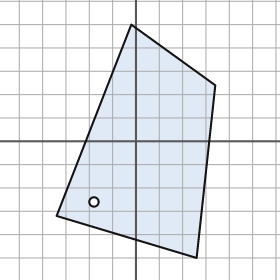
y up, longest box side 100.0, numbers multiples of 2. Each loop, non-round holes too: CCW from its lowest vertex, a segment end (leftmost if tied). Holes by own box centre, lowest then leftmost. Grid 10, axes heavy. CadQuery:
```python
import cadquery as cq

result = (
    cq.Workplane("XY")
    .moveTo(26.0, -50.0)
    .lineTo(34.0, 24.0)
    .lineTo(-2.0, 50.0)
    .lineTo(-34.0, -32.0)
    .close()
    .moveTo(-18.0, -26.0)
    .circle(2.0)
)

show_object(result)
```